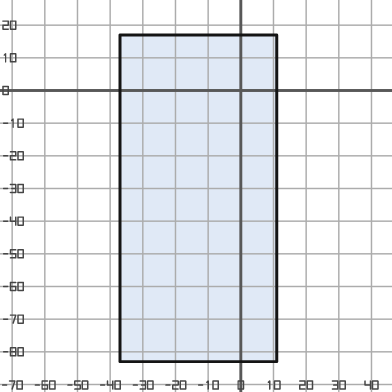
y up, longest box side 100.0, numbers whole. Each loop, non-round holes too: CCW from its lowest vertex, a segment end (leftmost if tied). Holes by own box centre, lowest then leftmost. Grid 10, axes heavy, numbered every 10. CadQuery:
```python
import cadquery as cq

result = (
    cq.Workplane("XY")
    .moveTo(-37.0, -83.0)
    .lineTo(11.0, -83.0)
    .lineTo(11.0, 17.0)
    .lineTo(-37.0, 17.0)
    .close()
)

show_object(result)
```